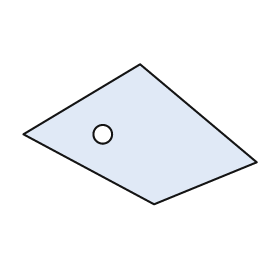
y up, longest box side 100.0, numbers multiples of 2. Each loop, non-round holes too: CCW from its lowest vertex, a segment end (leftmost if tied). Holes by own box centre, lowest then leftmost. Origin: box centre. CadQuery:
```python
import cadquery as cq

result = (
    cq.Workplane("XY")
    .moveTo(6.0, -30.0)
    .lineTo(50.0, -12.0)
    .lineTo(0.0, 30.0)
    .lineTo(-50.0, 0.0)
    .close()
    .moveTo(-16.0, 0.0)
    .circle(4.0)
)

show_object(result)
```